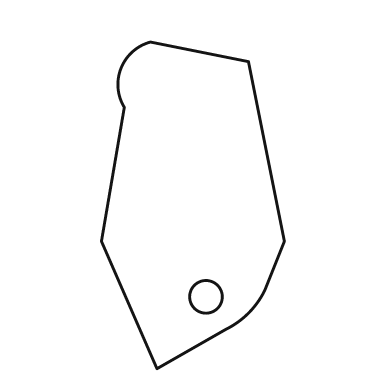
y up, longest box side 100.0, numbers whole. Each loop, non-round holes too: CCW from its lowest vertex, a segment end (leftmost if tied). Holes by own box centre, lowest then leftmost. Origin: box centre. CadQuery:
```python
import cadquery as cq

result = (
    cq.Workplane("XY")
    .moveTo(-11.0, -50.0)
    .lineTo(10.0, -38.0)
    .threePointArc((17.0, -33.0), (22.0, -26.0))
    .lineTo(28.0, -11.0)
    .lineTo(17.0, 44.0)
    .lineTo(-13.0, 50.0)
    .threePointArc((-22.0, 42.0), (-21.0, 30.0))
    .lineTo(-28.0, -11.0)
    .close()
    .moveTo(4.0, -28.0)
    .circle(5.0)
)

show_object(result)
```